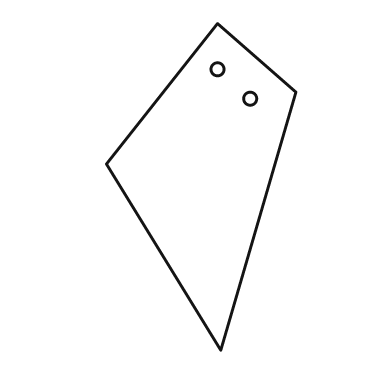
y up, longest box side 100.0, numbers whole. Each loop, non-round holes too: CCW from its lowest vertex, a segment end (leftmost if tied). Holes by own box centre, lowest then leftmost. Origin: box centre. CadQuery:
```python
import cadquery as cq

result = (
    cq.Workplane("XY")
    .moveTo(6.0, -50.0)
    .lineTo(29.0, 29.0)
    .lineTo(5.0, 50.0)
    .lineTo(-29.0, 7.0)
    .close()
    .moveTo(15.0, 27.0)
    .circle(2.0)
    .moveTo(5.0, 36.0)
    .circle(2.0)
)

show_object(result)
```